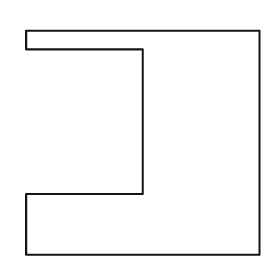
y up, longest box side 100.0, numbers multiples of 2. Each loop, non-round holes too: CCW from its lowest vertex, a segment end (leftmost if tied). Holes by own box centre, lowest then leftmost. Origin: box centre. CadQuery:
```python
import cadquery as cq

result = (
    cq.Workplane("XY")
    .moveTo(-50.0, -48.0)
    .lineTo(50.0, -48.0)
    .lineTo(50.0, 48.0)
    .lineTo(-50.0, 48.0)
    .lineTo(-50.0, 40.0)
    .lineTo(0.0, 40.0)
    .lineTo(0.0, -22.0)
    .lineTo(-50.0, -22.0)
    .close()
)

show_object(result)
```